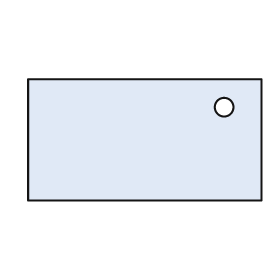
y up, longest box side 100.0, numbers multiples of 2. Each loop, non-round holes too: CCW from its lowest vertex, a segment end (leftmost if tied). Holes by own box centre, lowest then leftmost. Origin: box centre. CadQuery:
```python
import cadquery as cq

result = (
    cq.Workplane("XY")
    .moveTo(-50.0, -26.0)
    .lineTo(50.0, -26.0)
    .lineTo(50.0, 26.0)
    .lineTo(-50.0, 26.0)
    .close()
    .moveTo(34.0, 14.0)
    .circle(4.0)
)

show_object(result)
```